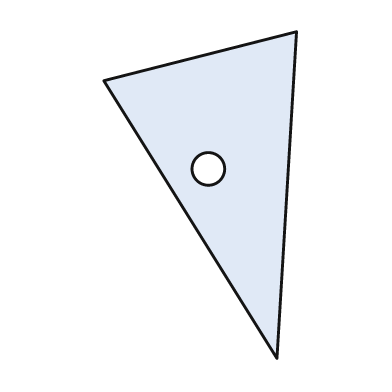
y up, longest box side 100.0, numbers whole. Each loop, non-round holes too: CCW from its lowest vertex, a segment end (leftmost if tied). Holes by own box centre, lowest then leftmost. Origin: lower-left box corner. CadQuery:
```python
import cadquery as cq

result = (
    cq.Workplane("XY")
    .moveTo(53.0, 0.0)
    .lineTo(59.0, 100.0)
    .lineTo(0.0, 85.0)
    .close()
    .moveTo(32.0, 58.0)
    .circle(5.0)
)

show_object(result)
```